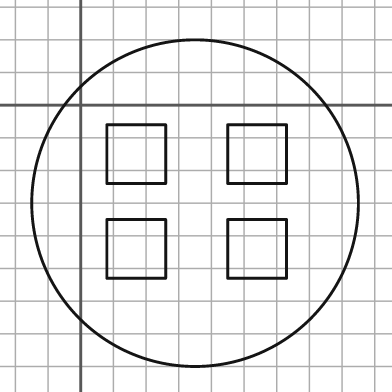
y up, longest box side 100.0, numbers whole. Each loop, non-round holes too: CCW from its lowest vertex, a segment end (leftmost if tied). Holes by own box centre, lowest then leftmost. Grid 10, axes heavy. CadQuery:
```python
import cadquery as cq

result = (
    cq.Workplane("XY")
    .moveTo(35.0, -30.0)
    .circle(50.0)
    .moveTo(8.0, -53.0)
    .lineTo(26.0, -53.0)
    .lineTo(26.0, -35.0)
    .lineTo(8.0, -35.0)
    .close()
    .moveTo(45.0, -53.0)
    .lineTo(63.0, -53.0)
    .lineTo(63.0, -35.0)
    .lineTo(45.0, -35.0)
    .close()
    .moveTo(8.0, -24.0)
    .lineTo(26.0, -24.0)
    .lineTo(26.0, -6.0)
    .lineTo(8.0, -6.0)
    .close()
    .moveTo(45.0, -24.0)
    .lineTo(63.0, -24.0)
    .lineTo(63.0, -6.0)
    .lineTo(45.0, -6.0)
    .close()
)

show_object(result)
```